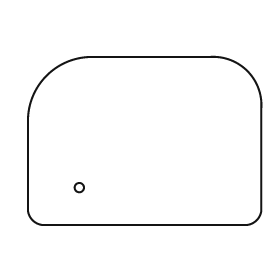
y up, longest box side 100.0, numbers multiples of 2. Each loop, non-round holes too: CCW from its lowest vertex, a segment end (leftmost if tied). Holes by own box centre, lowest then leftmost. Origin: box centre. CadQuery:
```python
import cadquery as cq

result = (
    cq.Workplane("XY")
    .moveTo(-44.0, -36.0)
    .lineTo(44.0, -36.0)
    .threePointArc((48.0, -34.0), (50.0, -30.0))
    .lineTo(50.0, 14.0)
    .threePointArc((44.0, 30.0), (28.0, 36.0))
    .lineTo(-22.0, 36.0)
    .threePointArc((-42.0, 28.0), (-50.0, 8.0))
    .lineTo(-50.0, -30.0)
    .threePointArc((-48.0, -34.0), (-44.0, -36.0))
    .close()
    .moveTo(-28.0, -20.0)
    .circle(2.0)
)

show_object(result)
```